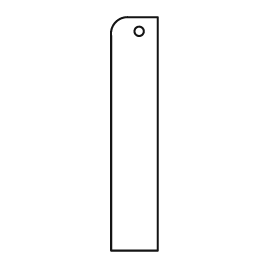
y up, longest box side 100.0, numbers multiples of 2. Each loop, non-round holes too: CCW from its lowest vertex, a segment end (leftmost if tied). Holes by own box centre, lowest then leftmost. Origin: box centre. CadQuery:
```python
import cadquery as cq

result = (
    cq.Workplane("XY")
    .moveTo(-10.0, -50.0)
    .lineTo(10.0, -50.0)
    .lineTo(10.0, 50.0)
    .lineTo(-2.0, 50.0)
    .threePointArc((-8.0, 48.0), (-10.0, 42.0))
    .close()
    .moveTo(2.0, 44.0)
    .circle(2.0)
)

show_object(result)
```